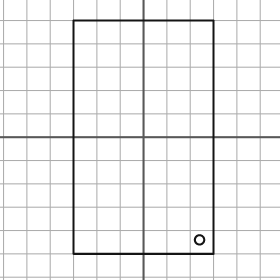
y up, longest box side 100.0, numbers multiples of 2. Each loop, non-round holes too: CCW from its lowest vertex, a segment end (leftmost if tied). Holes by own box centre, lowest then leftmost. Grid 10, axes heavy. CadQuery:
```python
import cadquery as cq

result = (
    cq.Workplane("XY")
    .moveTo(-30.0, -50.0)
    .lineTo(30.0, -50.0)
    .lineTo(30.0, 50.0)
    .lineTo(-30.0, 50.0)
    .close()
    .moveTo(24.0, -44.0)
    .circle(2.0)
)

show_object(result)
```